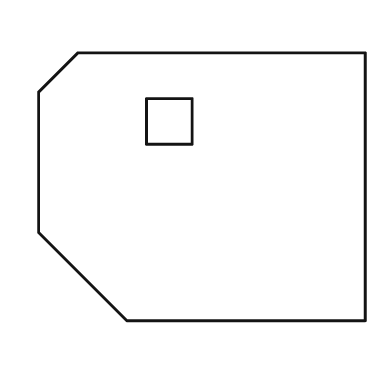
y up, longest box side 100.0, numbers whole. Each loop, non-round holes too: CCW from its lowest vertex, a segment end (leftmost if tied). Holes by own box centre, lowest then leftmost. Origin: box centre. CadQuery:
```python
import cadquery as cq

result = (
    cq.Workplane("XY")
    .moveTo(-23.0, -41.0)
    .lineTo(50.0, -41.0)
    .lineTo(50.0, 41.0)
    .lineTo(-38.0, 41.0)
    .lineTo(-50.0, 29.0)
    .lineTo(-50.0, -14.0)
    .close()
    .moveTo(-17.0, 13.0)
    .lineTo(-3.0, 13.0)
    .lineTo(-3.0, 27.0)
    .lineTo(-17.0, 27.0)
    .close()
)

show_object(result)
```